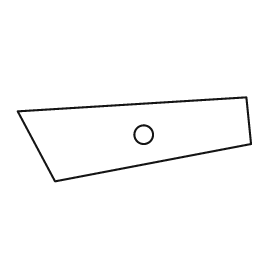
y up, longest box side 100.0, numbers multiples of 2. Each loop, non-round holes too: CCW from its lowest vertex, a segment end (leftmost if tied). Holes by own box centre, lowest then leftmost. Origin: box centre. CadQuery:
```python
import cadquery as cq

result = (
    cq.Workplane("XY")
    .moveTo(-34.0, -18.0)
    .lineTo(50.0, -2.0)
    .lineTo(48.0, 18.0)
    .lineTo(-50.0, 12.0)
    .close()
    .moveTo(4.0, 2.0)
    .circle(4.0)
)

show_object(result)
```